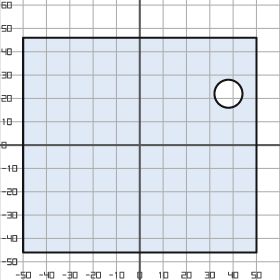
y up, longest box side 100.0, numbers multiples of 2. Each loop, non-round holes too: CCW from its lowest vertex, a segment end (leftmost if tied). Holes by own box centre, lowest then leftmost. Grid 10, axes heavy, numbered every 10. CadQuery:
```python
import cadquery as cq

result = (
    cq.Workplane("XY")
    .moveTo(-50.0, -46.0)
    .lineTo(50.0, -46.0)
    .lineTo(50.0, 46.0)
    .lineTo(-50.0, 46.0)
    .close()
    .moveTo(38.0, 22.0)
    .circle(6.0)
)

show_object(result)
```